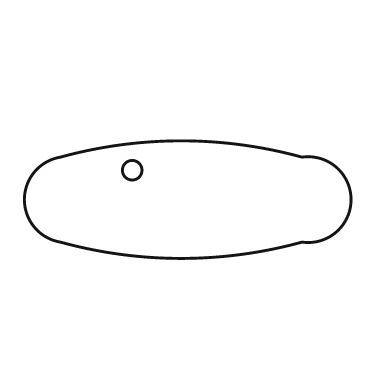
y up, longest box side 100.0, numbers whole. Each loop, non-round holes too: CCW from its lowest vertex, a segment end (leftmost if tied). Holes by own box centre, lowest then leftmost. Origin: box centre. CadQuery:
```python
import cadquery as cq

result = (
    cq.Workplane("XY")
    .moveTo(-39.0, -13.0)
    .threePointArc((-2.0, -18.0), (35.0, -13.0))
    .threePointArc((50.0, 0.0), (35.0, 13.0))
    .threePointArc((-2.0, 18.0), (-39.0, 13.0))
    .threePointArc((-50.0, 0.0), (-39.0, -13.0))
    .close()
    .moveTo(-17.0, 9.0)
    .circle(3.0)
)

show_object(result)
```